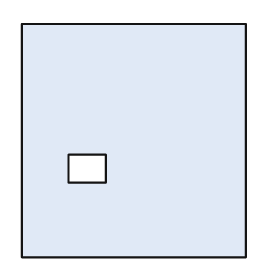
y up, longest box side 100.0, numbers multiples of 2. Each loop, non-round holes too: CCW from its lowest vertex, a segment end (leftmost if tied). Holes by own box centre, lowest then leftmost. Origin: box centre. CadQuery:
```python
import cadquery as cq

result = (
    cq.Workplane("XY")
    .moveTo(-48.0, -50.0)
    .lineTo(48.0, -50.0)
    .lineTo(48.0, 50.0)
    .lineTo(-48.0, 50.0)
    .close()
    .moveTo(-28.0, -18.0)
    .lineTo(-12.0, -18.0)
    .lineTo(-12.0, -6.0)
    .lineTo(-28.0, -6.0)
    .close()
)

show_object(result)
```